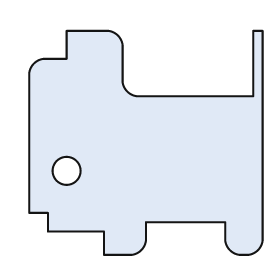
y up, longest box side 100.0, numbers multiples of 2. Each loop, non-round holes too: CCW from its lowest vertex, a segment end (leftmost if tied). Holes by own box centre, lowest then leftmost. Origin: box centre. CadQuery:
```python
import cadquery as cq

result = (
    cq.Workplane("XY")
    .moveTo(-18.0, -48.0)
    .lineTo(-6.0, -48.0)
    .threePointArc((-2.0, -46.0), (0.0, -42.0))
    .lineTo(0.0, -34.0)
    .lineTo(34.0, -34.0)
    .lineTo(34.0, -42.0)
    .threePointArc((36.0, -46.0), (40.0, -48.0))
    .lineTo(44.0, -48.0)
    .threePointArc((48.0, -46.0), (50.0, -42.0))
    .lineTo(50.0, 48.0)
    .lineTo(46.0, 48.0)
    .lineTo(46.0, 20.0)
    .lineTo(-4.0, 20.0)
    .threePointArc((-8.0, 22.0), (-10.0, 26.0))
    .lineTo(-10.0, 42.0)
    .threePointArc((-12.0, 46.0), (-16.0, 48.0))
    .lineTo(-34.0, 48.0)
    .lineTo(-34.0, 36.0)
    .lineTo(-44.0, 36.0)
    .threePointArc((-48.0, 34.0), (-50.0, 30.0))
    .lineTo(-50.0, -30.0)
    .lineTo(-42.0, -30.0)
    .lineTo(-42.0, -38.0)
    .lineTo(-18.0, -38.0)
    .close()
    .moveTo(-34.0, -12.0)
    .circle(6.0)
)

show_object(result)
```